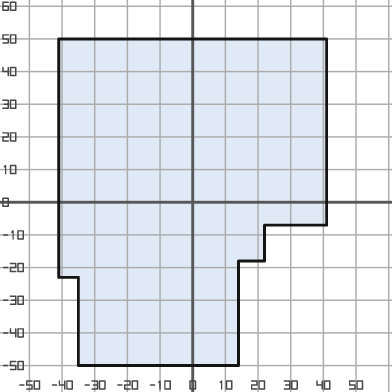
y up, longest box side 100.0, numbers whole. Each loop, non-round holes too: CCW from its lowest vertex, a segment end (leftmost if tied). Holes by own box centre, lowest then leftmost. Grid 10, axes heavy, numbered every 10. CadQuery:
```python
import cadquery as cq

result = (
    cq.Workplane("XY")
    .moveTo(-35.0, -50.0)
    .lineTo(14.0, -50.0)
    .lineTo(14.0, -18.0)
    .lineTo(22.0, -18.0)
    .lineTo(22.0, -7.0)
    .lineTo(41.0, -7.0)
    .lineTo(41.0, 50.0)
    .lineTo(-41.0, 50.0)
    .lineTo(-41.0, -23.0)
    .lineTo(-35.0, -23.0)
    .close()
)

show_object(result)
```